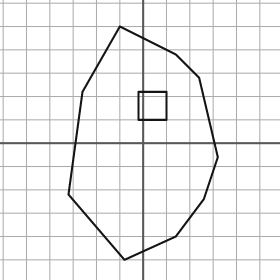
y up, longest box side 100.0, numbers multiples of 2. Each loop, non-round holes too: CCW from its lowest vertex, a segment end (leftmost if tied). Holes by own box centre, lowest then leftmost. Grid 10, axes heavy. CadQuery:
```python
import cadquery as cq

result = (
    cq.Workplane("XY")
    .moveTo(-8.0, -50.0)
    .lineTo(14.0, -40.0)
    .lineTo(26.0, -24.0)
    .lineTo(32.0, -6.0)
    .lineTo(24.0, 28.0)
    .lineTo(14.0, 38.0)
    .lineTo(-10.0, 50.0)
    .lineTo(-26.0, 22.0)
    .lineTo(-32.0, -22.0)
    .close()
    .moveTo(-2.0, 10.0)
    .lineTo(10.0, 10.0)
    .lineTo(10.0, 22.0)
    .lineTo(-2.0, 22.0)
    .close()
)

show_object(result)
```